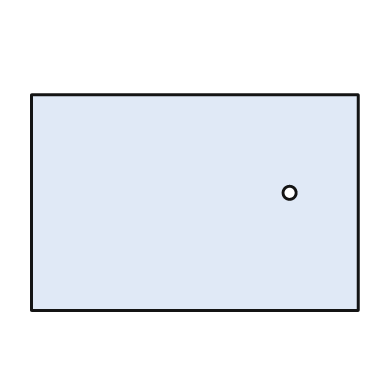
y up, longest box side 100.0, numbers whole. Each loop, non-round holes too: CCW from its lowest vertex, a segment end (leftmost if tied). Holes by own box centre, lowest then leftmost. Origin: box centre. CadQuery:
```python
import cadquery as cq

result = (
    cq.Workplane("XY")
    .moveTo(-50.0, -33.0)
    .lineTo(50.0, -33.0)
    .lineTo(50.0, 33.0)
    .lineTo(-50.0, 33.0)
    .close()
    .moveTo(29.0, 3.0)
    .circle(2.0)
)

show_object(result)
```